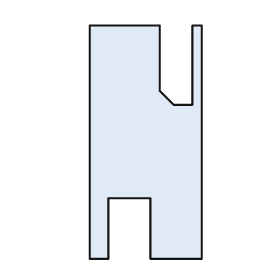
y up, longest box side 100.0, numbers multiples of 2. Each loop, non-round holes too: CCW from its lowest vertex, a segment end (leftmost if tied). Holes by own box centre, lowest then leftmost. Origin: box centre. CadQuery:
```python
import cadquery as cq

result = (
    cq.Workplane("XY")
    .moveTo(-24.0, -50.0)
    .lineTo(-16.0, -50.0)
    .lineTo(-16.0, -24.0)
    .lineTo(2.0, -24.0)
    .lineTo(2.0, -50.0)
    .lineTo(24.0, -50.0)
    .lineTo(24.0, 50.0)
    .lineTo(20.0, 50.0)
    .lineTo(20.0, 16.0)
    .lineTo(12.0, 16.0)
    .lineTo(6.0, 22.0)
    .lineTo(6.0, 50.0)
    .lineTo(-24.0, 50.0)
    .close()
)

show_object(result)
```